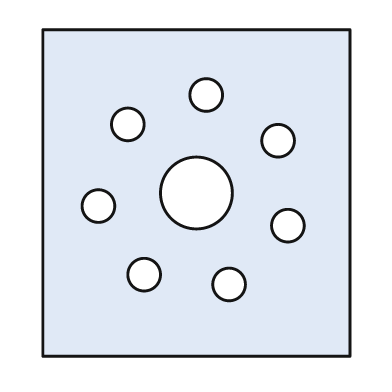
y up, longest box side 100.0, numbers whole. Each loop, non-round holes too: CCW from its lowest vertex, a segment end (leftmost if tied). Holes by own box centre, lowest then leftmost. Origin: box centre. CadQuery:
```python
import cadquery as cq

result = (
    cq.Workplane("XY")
    .moveTo(-47.0, -50.0)
    .lineTo(47.0, -50.0)
    .lineTo(47.0, 50.0)
    .lineTo(-47.0, 50.0)
    .close()
    .moveTo(10.0, -28.0)
    .circle(5.0)
    .moveTo(-16.0, -25.0)
    .circle(5.0)
    .moveTo(28.0, -10.0)
    .circle(5.0)
    .moveTo(-30.0, -4.0)
    .circle(5.0)
    .moveTo(0.0, 0.0)
    .circle(11.0)
    .moveTo(25.0, 16.0)
    .circle(5.0)
    .moveTo(-21.0, 21.0)
    .circle(5.0)
    .moveTo(3.0, 30.0)
    .circle(5.0)
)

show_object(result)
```